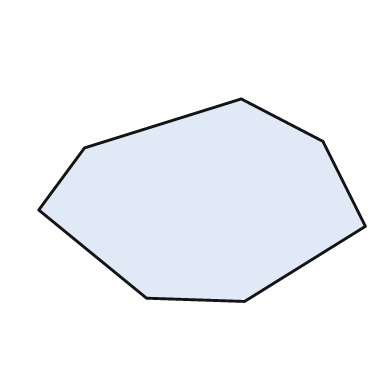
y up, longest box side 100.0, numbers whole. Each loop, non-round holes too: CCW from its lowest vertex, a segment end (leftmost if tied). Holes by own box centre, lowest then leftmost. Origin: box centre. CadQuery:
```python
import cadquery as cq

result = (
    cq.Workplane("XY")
    .moveTo(13.0, -31.0)
    .lineTo(50.0, -8.0)
    .lineTo(37.0, 18.0)
    .lineTo(12.0, 31.0)
    .lineTo(-36.0, 16.0)
    .lineTo(-50.0, -3.0)
    .lineTo(-17.0, -30.0)
    .close()
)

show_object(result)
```